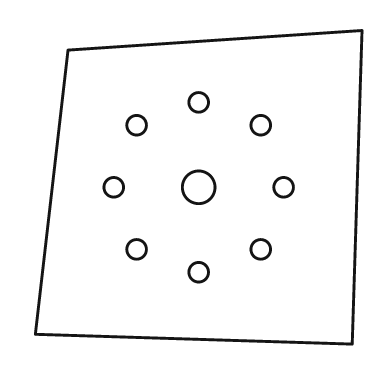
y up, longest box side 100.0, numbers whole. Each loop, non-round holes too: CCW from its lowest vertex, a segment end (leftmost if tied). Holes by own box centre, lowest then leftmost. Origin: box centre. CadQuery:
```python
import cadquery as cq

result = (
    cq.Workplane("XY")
    .moveTo(47.0, -48.0)
    .lineTo(50.0, 48.0)
    .lineTo(-40.0, 42.0)
    .lineTo(-50.0, -45.0)
    .close()
    .moveTo(0.0, -26.0)
    .circle(3.0)
    .moveTo(-19.0, -19.0)
    .circle(3.0)
    .moveTo(19.0, -19.0)
    .circle(3.0)
    .moveTo(-26.0, 0.0)
    .circle(3.0)
    .moveTo(0.0, 0.0)
    .circle(5.0)
    .moveTo(26.0, 0.0)
    .circle(3.0)
    .moveTo(-19.0, 19.0)
    .circle(3.0)
    .moveTo(19.0, 19.0)
    .circle(3.0)
    .moveTo(0.0, 26.0)
    .circle(3.0)
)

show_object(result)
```